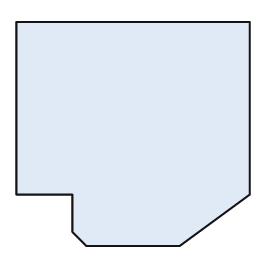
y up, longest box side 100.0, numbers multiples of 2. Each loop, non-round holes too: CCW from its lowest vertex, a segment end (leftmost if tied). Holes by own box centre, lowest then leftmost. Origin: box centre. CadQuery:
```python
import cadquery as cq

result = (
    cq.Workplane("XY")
    .moveTo(-20.0, -48.0)
    .lineTo(20.0, -48.0)
    .lineTo(50.0, -26.0)
    .lineTo(50.0, 48.0)
    .lineTo(-50.0, 48.0)
    .lineTo(-50.0, -26.0)
    .lineTo(-26.0, -26.0)
    .lineTo(-26.0, -42.0)
    .close()
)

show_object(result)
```